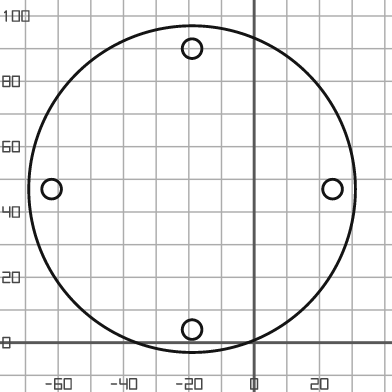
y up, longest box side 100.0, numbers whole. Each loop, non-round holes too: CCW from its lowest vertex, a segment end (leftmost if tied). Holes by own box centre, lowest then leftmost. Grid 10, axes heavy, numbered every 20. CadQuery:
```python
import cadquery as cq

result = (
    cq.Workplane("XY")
    .moveTo(-19.0, 47.0)
    .circle(50.0)
    .moveTo(-19.0, 4.0)
    .circle(3.0)
    .moveTo(-62.0, 47.0)
    .circle(3.0)
    .moveTo(24.0, 47.0)
    .circle(3.0)
    .moveTo(-19.0, 90.0)
    .circle(3.0)
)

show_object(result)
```